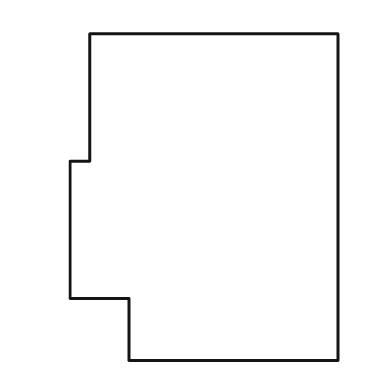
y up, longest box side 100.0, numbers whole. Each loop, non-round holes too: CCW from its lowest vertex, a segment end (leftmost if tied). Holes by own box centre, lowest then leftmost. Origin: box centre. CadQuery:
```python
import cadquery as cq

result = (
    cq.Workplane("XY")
    .moveTo(-23.0, -50.0)
    .lineTo(41.0, -50.0)
    .lineTo(41.0, 50.0)
    .lineTo(-35.0, 50.0)
    .lineTo(-35.0, 11.0)
    .lineTo(-41.0, 11.0)
    .lineTo(-41.0, -31.0)
    .lineTo(-23.0, -31.0)
    .close()
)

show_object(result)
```